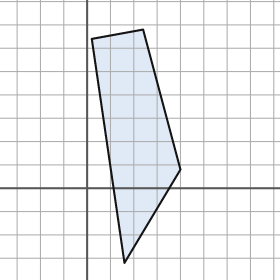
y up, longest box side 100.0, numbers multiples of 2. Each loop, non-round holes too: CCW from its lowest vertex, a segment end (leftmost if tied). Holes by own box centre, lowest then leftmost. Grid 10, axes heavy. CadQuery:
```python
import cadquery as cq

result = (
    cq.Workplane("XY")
    .moveTo(16.0, -32.0)
    .lineTo(40.0, 8.0)
    .lineTo(24.0, 68.0)
    .lineTo(2.0, 64.0)
    .close()
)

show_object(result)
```